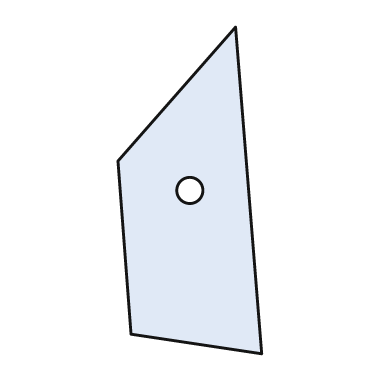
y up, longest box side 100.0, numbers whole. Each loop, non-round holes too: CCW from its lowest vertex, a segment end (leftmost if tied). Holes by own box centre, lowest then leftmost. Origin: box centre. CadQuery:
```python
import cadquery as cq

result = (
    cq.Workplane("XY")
    .moveTo(22.0, -50.0)
    .lineTo(14.0, 50.0)
    .lineTo(-22.0, 9.0)
    .lineTo(-18.0, -44.0)
    .close()
    .moveTo(0.0, 0.0)
    .circle(4.0)
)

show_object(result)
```